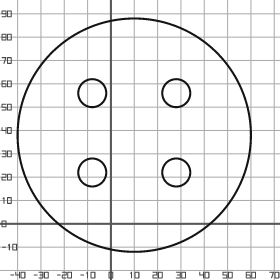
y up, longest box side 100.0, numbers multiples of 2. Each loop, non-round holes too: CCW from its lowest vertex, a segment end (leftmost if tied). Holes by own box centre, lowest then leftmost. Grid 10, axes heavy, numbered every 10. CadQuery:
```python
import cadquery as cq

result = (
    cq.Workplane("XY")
    .moveTo(10.0, 38.0)
    .circle(50.0)
    .moveTo(-8.0, 22.0)
    .circle(6.0)
    .moveTo(28.0, 22.0)
    .circle(6.0)
    .moveTo(-8.0, 56.0)
    .circle(6.0)
    .moveTo(28.0, 56.0)
    .circle(6.0)
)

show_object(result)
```